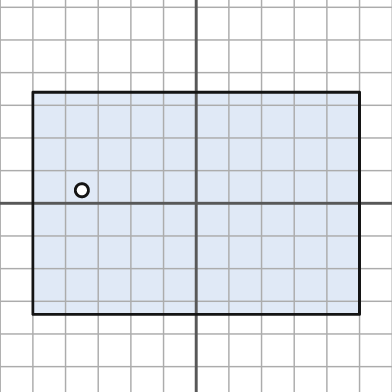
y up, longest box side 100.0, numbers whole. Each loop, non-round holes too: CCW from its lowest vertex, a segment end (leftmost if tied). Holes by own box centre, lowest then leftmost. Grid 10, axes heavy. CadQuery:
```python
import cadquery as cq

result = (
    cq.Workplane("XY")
    .moveTo(-50.0, -34.0)
    .lineTo(50.0, -34.0)
    .lineTo(50.0, 34.0)
    .lineTo(-50.0, 34.0)
    .close()
    .moveTo(-35.0, 4.0)
    .circle(2.0)
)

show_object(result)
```